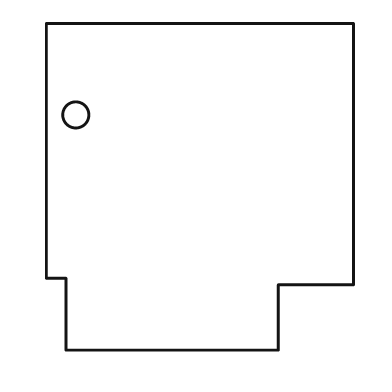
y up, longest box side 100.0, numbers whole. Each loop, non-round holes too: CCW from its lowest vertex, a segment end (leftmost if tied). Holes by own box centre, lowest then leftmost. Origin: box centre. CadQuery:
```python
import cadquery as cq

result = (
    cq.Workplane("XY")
    .moveTo(-41.0, -50.0)
    .lineTo(24.0, -50.0)
    .lineTo(24.0, -30.0)
    .lineTo(47.0, -30.0)
    .lineTo(47.0, 50.0)
    .lineTo(-47.0, 50.0)
    .lineTo(-47.0, -28.0)
    .lineTo(-41.0, -28.0)
    .close()
    .moveTo(-38.0, 22.0)
    .circle(4.0)
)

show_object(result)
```